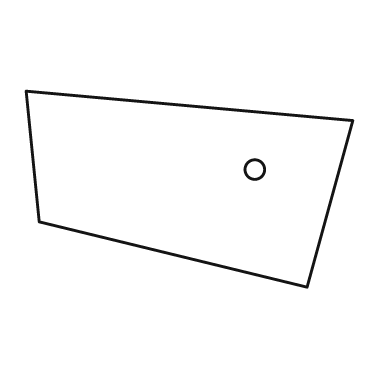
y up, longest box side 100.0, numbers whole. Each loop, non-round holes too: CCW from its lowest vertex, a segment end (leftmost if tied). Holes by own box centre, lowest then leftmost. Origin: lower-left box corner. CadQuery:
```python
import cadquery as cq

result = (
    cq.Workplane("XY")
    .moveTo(86.0, 0.0)
    .lineTo(100.0, 51.0)
    .lineTo(0.0, 60.0)
    .lineTo(4.0, 20.0)
    .close()
    .moveTo(70.0, 36.0)
    .circle(3.0)
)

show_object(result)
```